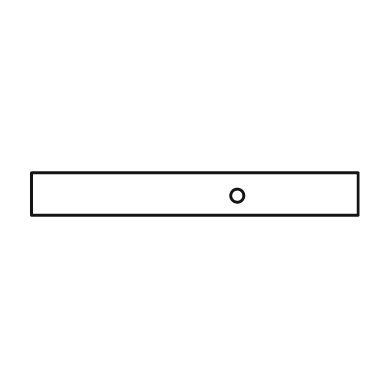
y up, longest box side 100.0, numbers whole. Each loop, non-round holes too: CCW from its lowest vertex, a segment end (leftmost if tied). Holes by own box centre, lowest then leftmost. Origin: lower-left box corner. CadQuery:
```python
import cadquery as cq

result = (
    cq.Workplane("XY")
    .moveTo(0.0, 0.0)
    .lineTo(100.0, 0.0)
    .lineTo(100.0, 13.0)
    .lineTo(0.0, 13.0)
    .close()
    .moveTo(63.0, 6.0)
    .circle(2.0)
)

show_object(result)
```